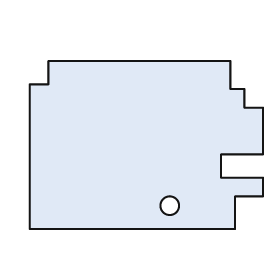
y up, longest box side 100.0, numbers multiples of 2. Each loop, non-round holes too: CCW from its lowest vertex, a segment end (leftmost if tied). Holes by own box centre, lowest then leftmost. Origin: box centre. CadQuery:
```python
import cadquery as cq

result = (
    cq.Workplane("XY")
    .moveTo(-50.0, -36.0)
    .lineTo(38.0, -36.0)
    .lineTo(38.0, -22.0)
    .lineTo(50.0, -22.0)
    .lineTo(50.0, -14.0)
    .lineTo(32.0, -14.0)
    .lineTo(32.0, -4.0)
    .lineTo(50.0, -4.0)
    .lineTo(50.0, 16.0)
    .lineTo(42.0, 16.0)
    .lineTo(42.0, 24.0)
    .lineTo(36.0, 24.0)
    .lineTo(36.0, 36.0)
    .lineTo(-42.0, 36.0)
    .lineTo(-42.0, 26.0)
    .lineTo(-50.0, 26.0)
    .close()
    .moveTo(10.0, -26.0)
    .circle(4.0)
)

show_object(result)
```